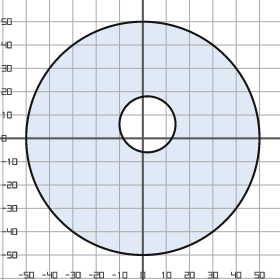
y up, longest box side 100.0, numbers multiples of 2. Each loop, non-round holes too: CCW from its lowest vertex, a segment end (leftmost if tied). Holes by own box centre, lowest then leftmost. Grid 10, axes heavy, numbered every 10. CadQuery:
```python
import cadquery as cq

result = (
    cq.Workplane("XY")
    .moveTo(0.0, 0.0)
    .circle(50.0)
    .moveTo(2.0, 6.0)
    .circle(12.0)
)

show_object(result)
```